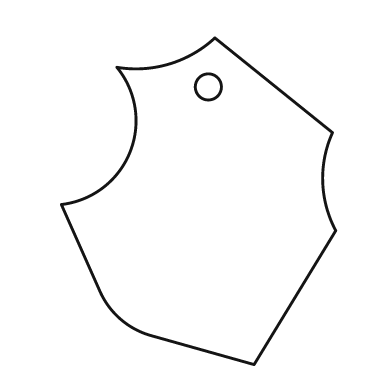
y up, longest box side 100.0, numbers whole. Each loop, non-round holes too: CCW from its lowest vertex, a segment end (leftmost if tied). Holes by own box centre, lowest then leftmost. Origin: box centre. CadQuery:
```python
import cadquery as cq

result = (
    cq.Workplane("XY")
    .moveTo(17.0, -50.0)
    .lineTo(42.0, -9.0)
    .threePointArc((38.0, 6.0), (41.0, 21.0))
    .lineTo(5.0, 50.0)
    .threePointArc((-9.0, 42.0), (-25.0, 41.0))
    .threePointArc((-21.0, 15.0), (-42.0, -1.0))
    .lineTo(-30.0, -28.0)
    .threePointArc((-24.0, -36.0), (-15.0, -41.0))
    .close()
    .moveTo(3.0, 35.0)
    .circle(4.0)
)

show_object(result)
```